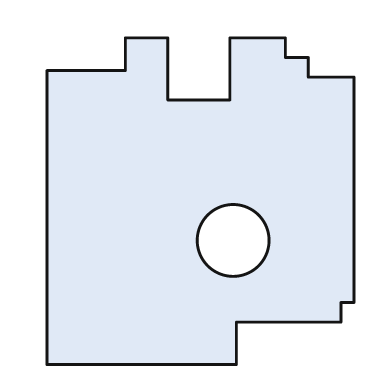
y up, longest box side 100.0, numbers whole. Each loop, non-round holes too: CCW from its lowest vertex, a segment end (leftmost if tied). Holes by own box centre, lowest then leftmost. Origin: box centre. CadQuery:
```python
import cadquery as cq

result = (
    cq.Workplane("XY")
    .moveTo(-47.0, -50.0)
    .lineTo(11.0, -50.0)
    .lineTo(11.0, -37.0)
    .lineTo(43.0, -37.0)
    .lineTo(43.0, -31.0)
    .lineTo(47.0, -31.0)
    .lineTo(47.0, 38.0)
    .lineTo(33.0, 38.0)
    .lineTo(33.0, 44.0)
    .lineTo(26.0, 44.0)
    .lineTo(26.0, 50.0)
    .lineTo(9.0, 50.0)
    .lineTo(9.0, 31.0)
    .lineTo(-10.0, 31.0)
    .lineTo(-10.0, 50.0)
    .lineTo(-23.0, 50.0)
    .lineTo(-23.0, 40.0)
    .lineTo(-47.0, 40.0)
    .close()
    .moveTo(10.0, -12.0)
    .circle(11.0)
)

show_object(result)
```